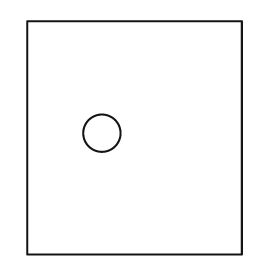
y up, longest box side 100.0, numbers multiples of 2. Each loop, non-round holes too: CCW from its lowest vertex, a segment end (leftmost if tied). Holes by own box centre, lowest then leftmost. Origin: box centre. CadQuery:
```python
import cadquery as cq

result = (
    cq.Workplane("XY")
    .moveTo(-46.0, -50.0)
    .lineTo(46.0, -50.0)
    .lineTo(46.0, 50.0)
    .lineTo(-46.0, 50.0)
    .close()
    .moveTo(-14.0, 2.0)
    .circle(8.0)
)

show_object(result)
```